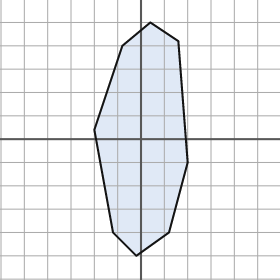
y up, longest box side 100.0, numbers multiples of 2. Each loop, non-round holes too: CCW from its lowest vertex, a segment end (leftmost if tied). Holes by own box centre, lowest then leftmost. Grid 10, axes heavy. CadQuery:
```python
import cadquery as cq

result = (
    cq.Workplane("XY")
    .moveTo(-2.0, -50.0)
    .lineTo(12.0, -40.0)
    .lineTo(20.0, -10.0)
    .lineTo(16.0, 42.0)
    .lineTo(4.0, 50.0)
    .lineTo(-8.0, 40.0)
    .lineTo(-20.0, 4.0)
    .lineTo(-12.0, -40.0)
    .close()
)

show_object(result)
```